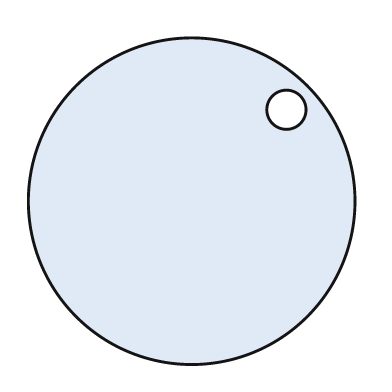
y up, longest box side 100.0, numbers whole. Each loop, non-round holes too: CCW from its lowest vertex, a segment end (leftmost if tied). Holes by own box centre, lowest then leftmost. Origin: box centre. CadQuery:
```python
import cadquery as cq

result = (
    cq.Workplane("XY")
    .moveTo(0.0, 0.0)
    .circle(50.0)
    .moveTo(29.0, 28.0)
    .circle(6.0)
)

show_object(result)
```